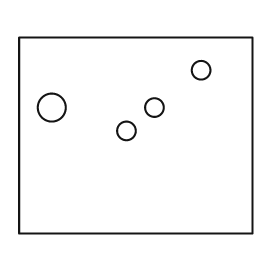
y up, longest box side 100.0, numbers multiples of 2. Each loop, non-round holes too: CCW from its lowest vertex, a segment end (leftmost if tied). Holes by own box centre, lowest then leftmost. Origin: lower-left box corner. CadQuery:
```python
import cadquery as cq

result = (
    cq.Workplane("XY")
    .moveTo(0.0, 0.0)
    .lineTo(100.0, 0.0)
    .lineTo(100.0, 84.0)
    .lineTo(0.0, 84.0)
    .close()
    .moveTo(46.0, 44.0)
    .circle(4.0)
    .moveTo(14.0, 54.0)
    .circle(6.0)
    .moveTo(58.0, 54.0)
    .circle(4.0)
    .moveTo(78.0, 70.0)
    .circle(4.0)
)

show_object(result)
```